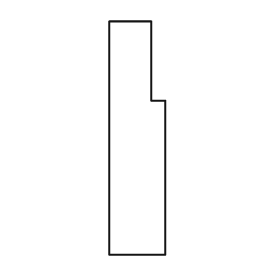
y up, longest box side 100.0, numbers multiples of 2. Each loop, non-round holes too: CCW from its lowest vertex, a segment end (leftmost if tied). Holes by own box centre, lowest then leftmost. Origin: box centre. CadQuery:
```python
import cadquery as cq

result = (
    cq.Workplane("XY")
    .moveTo(-12.0, -50.0)
    .lineTo(12.0, -50.0)
    .lineTo(12.0, 16.0)
    .lineTo(6.0, 16.0)
    .lineTo(6.0, 50.0)
    .lineTo(-12.0, 50.0)
    .close()
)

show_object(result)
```